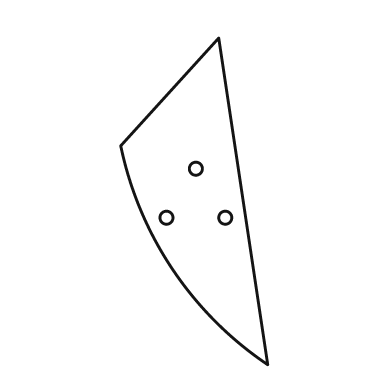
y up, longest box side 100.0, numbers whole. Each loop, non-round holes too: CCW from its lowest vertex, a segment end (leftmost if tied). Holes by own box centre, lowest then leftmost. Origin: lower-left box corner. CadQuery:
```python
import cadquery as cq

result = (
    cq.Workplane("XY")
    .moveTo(45.0, 0.0)
    .lineTo(30.0, 100.0)
    .lineTo(0.0, 67.0)
    .threePointArc((16.0, 29.0), (45.0, 0.0))
    .close()
    .moveTo(14.0, 45.0)
    .circle(2.0)
    .moveTo(32.0, 45.0)
    .circle(2.0)
    .moveTo(23.0, 60.0)
    .circle(2.0)
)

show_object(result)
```